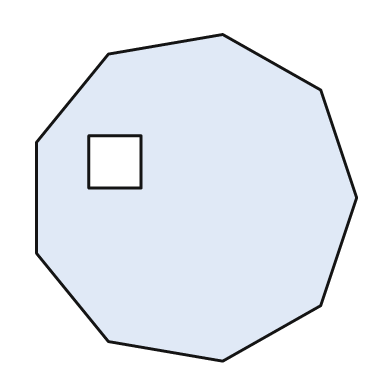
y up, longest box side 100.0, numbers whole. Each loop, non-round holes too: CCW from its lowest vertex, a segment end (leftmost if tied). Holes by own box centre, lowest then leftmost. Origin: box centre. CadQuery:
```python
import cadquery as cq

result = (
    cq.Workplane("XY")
    .moveTo(8.0, -50.0)
    .lineTo(38.0, -33.0)
    .lineTo(49.0, 0.0)
    .lineTo(38.0, 33.0)
    .lineTo(8.0, 50.0)
    .lineTo(-27.0, 44.0)
    .lineTo(-49.0, 17.0)
    .lineTo(-49.0, -17.0)
    .lineTo(-27.0, -44.0)
    .close()
    .moveTo(-33.0, 3.0)
    .lineTo(-17.0, 3.0)
    .lineTo(-17.0, 19.0)
    .lineTo(-33.0, 19.0)
    .close()
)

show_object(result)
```